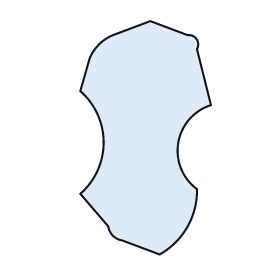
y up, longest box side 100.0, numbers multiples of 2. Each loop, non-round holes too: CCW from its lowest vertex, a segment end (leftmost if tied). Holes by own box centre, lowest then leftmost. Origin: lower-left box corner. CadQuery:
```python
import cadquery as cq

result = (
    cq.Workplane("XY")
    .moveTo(34.0, 0.0)
    .threePointArc((46.0, 12.0), (50.0, 28.0))
    .threePointArc((42.0, 48.0), (56.0, 64.0))
    .lineTo(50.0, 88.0)
    .threePointArc((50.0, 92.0), (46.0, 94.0))
    .lineTo(30.0, 100.0)
    .lineTo(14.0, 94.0)
    .threePointArc((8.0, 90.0), (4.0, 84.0))
    .lineTo(0.0, 70.0)
    .threePointArc((10.0, 48.0), (0.0, 26.0))
    .lineTo(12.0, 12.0)
    .threePointArc((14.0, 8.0), (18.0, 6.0))
    .close()
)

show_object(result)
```